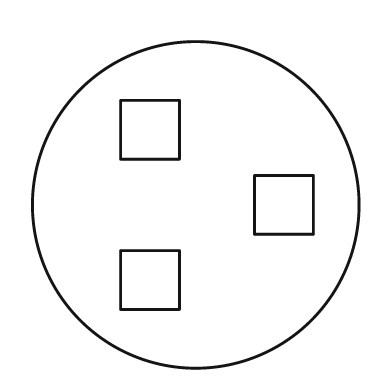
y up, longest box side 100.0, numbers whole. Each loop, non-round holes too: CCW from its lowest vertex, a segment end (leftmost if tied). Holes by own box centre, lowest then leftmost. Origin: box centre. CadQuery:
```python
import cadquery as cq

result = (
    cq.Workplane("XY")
    .moveTo(0.0, 0.0)
    .circle(50.0)
    .moveTo(-23.0, -32.0)
    .lineTo(-5.0, -32.0)
    .lineTo(-5.0, -14.0)
    .lineTo(-23.0, -14.0)
    .close()
    .moveTo(18.0, -9.0)
    .lineTo(36.0, -9.0)
    .lineTo(36.0, 9.0)
    .lineTo(18.0, 9.0)
    .close()
    .moveTo(-23.0, 14.0)
    .lineTo(-5.0, 14.0)
    .lineTo(-5.0, 32.0)
    .lineTo(-23.0, 32.0)
    .close()
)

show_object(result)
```